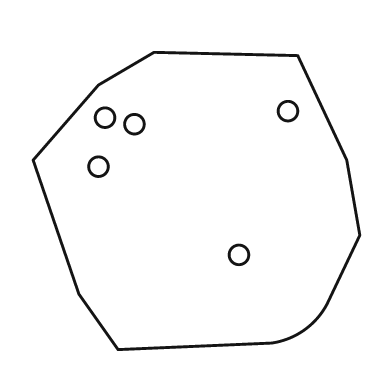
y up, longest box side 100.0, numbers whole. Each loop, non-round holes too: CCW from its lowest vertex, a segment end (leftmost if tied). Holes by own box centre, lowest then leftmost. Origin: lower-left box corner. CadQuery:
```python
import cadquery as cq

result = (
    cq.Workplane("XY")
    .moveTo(26.0, 0.0)
    .lineTo(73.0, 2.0)
    .threePointArc((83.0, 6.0), (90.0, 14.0))
    .lineTo(100.0, 35.0)
    .lineTo(96.0, 58.0)
    .lineTo(81.0, 90.0)
    .lineTo(37.0, 91.0)
    .lineTo(20.0, 81.0)
    .lineTo(0.0, 58.0)
    .lineTo(14.0, 17.0)
    .close()
    .moveTo(63.0, 29.0)
    .circle(3.0)
    .moveTo(20.0, 56.0)
    .circle(3.0)
    .moveTo(31.0, 69.0)
    .circle(3.0)
    .moveTo(22.0, 71.0)
    .circle(3.0)
    .moveTo(78.0, 73.0)
    .circle(3.0)
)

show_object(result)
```